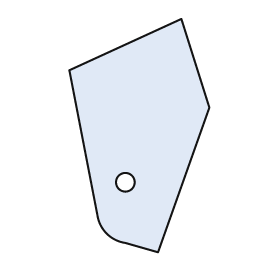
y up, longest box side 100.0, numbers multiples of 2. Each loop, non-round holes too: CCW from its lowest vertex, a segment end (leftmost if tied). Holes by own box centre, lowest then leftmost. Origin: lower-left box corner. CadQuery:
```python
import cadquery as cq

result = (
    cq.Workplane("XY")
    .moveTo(38.0, 0.0)
    .lineTo(60.0, 62.0)
    .lineTo(48.0, 100.0)
    .lineTo(0.0, 78.0)
    .lineTo(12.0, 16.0)
    .threePointArc((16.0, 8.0), (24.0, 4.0))
    .close()
    .moveTo(24.0, 30.0)
    .circle(4.0)
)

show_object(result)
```